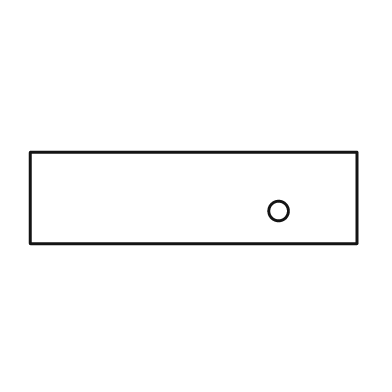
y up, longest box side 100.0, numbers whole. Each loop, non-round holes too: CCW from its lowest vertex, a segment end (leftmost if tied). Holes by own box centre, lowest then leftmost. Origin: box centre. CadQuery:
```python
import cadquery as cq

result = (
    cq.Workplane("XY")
    .moveTo(-50.0, -14.0)
    .lineTo(50.0, -14.0)
    .lineTo(50.0, 14.0)
    .lineTo(-50.0, 14.0)
    .close()
    .moveTo(26.0, -4.0)
    .circle(3.0)
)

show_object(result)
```